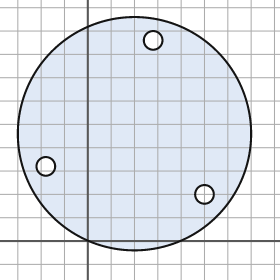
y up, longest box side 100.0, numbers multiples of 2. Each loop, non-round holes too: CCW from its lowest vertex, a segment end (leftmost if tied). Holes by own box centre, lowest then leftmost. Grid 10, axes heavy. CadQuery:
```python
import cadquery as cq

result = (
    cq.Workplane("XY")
    .moveTo(20.0, 46.0)
    .circle(50.0)
    .moveTo(50.0, 20.0)
    .circle(4.0)
    .moveTo(-18.0, 32.0)
    .circle(4.0)
    .moveTo(28.0, 86.0)
    .circle(4.0)
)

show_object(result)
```